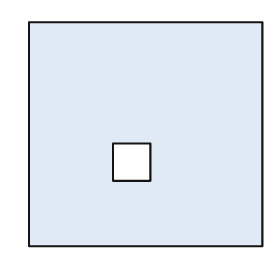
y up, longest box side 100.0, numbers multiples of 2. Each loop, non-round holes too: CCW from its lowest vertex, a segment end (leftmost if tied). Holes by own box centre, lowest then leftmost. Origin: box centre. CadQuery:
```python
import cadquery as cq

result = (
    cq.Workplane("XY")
    .moveTo(-50.0, -48.0)
    .lineTo(50.0, -48.0)
    .lineTo(50.0, 48.0)
    .lineTo(-50.0, 48.0)
    .close()
    .moveTo(-14.0, -20.0)
    .lineTo(2.0, -20.0)
    .lineTo(2.0, -4.0)
    .lineTo(-14.0, -4.0)
    .close()
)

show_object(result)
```